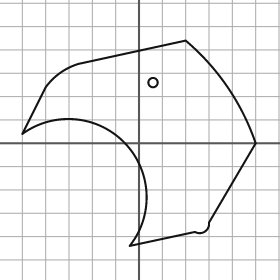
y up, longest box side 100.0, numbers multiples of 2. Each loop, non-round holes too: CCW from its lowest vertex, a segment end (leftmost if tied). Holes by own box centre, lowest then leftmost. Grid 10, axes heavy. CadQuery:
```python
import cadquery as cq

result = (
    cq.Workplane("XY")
    .moveTo(-4.0, -44.0)
    .lineTo(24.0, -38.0)
    .threePointArc((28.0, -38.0), (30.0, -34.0))
    .lineTo(50.0, 0.0)
    .threePointArc((38.0, 24.0), (20.0, 44.0))
    .lineTo(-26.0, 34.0)
    .threePointArc((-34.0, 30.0), (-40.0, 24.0))
    .lineTo(-50.0, 4.0)
    .threePointArc((-6.0, 0.0), (-4.0, -44.0))
    .close()
    .moveTo(6.0, 26.0)
    .circle(2.0)
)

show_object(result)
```